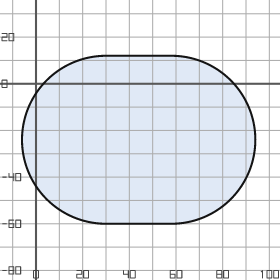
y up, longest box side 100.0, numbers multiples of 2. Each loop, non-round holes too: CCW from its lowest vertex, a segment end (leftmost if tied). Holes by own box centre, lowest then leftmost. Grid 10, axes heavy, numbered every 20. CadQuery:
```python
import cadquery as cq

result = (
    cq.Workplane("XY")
    .moveTo(30.0, -60.0)
    .lineTo(58.0, -60.0)
    .threePointArc((94.0, -24.0), (58.0, 12.0))
    .lineTo(30.0, 12.0)
    .threePointArc((-6.0, -24.0), (30.0, -60.0))
    .close()
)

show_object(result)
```